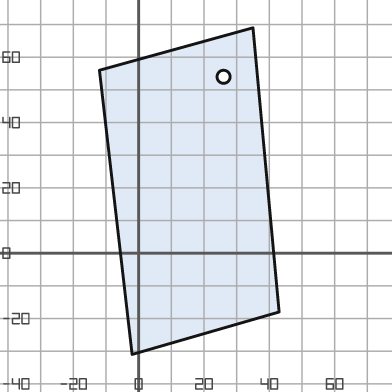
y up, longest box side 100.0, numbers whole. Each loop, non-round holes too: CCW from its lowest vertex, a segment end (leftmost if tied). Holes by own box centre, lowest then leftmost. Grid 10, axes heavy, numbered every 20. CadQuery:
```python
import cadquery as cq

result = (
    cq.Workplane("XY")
    .moveTo(-2.0, -31.0)
    .lineTo(43.0, -18.0)
    .lineTo(35.0, 69.0)
    .lineTo(-12.0, 56.0)
    .close()
    .moveTo(26.0, 54.0)
    .circle(2.0)
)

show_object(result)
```